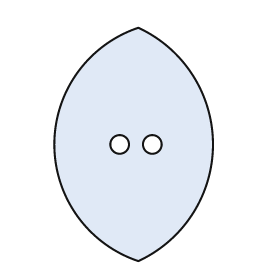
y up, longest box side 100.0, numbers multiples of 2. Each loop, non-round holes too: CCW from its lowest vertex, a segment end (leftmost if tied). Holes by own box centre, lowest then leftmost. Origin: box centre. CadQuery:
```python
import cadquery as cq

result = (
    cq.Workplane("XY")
    .moveTo(2.0, -50.0)
    .threePointArc((34.0, 0.0), (2.0, 50.0))
    .threePointArc((-34.0, 0.0), (2.0, -50.0))
    .close()
    .moveTo(-6.0, 0.0)
    .circle(4.0)
    .moveTo(8.0, 0.0)
    .circle(4.0)
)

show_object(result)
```